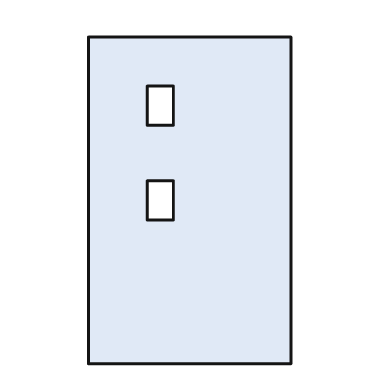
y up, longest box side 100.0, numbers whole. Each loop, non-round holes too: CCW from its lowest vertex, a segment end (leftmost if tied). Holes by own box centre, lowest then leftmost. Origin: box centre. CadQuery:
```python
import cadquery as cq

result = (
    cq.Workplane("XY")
    .moveTo(-31.0, -50.0)
    .lineTo(31.0, -50.0)
    .lineTo(31.0, 50.0)
    .lineTo(-31.0, 50.0)
    .close()
    .moveTo(-13.0, -6.0)
    .lineTo(-5.0, -6.0)
    .lineTo(-5.0, 6.0)
    .lineTo(-13.0, 6.0)
    .close()
    .moveTo(-13.0, 23.0)
    .lineTo(-5.0, 23.0)
    .lineTo(-5.0, 35.0)
    .lineTo(-13.0, 35.0)
    .close()
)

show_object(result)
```